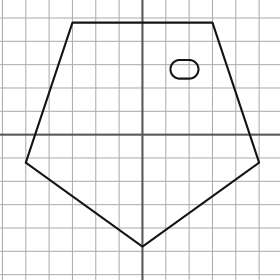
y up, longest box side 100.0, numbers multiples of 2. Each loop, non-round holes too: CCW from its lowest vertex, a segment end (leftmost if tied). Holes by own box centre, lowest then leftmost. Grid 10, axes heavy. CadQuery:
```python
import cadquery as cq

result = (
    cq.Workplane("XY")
    .moveTo(0.0, -48.0)
    .lineTo(50.0, -12.0)
    .lineTo(30.0, 48.0)
    .lineTo(-30.0, 48.0)
    .lineTo(-50.0, -12.0)
    .close()
    .moveTo(16.0, 24.0)
    .lineTo(20.0, 24.0)
    .threePointArc((24.0, 28.0), (20.0, 32.0))
    .lineTo(16.0, 32.0)
    .threePointArc((12.0, 28.0), (16.0, 24.0))
    .close()
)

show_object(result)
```